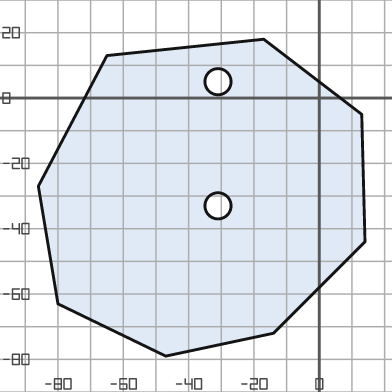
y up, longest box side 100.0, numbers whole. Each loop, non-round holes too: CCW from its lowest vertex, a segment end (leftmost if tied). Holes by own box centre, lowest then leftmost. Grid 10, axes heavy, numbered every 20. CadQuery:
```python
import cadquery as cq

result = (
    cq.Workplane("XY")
    .moveTo(-47.0, -79.0)
    .lineTo(-14.0, -72.0)
    .lineTo(14.0, -44.0)
    .lineTo(13.0, -5.0)
    .lineTo(-17.0, 18.0)
    .lineTo(-65.0, 13.0)
    .lineTo(-86.0, -27.0)
    .lineTo(-80.0, -63.0)
    .close()
    .moveTo(-31.0, -33.0)
    .circle(4.0)
    .moveTo(-31.0, 5.0)
    .circle(4.0)
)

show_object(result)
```